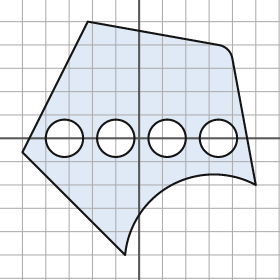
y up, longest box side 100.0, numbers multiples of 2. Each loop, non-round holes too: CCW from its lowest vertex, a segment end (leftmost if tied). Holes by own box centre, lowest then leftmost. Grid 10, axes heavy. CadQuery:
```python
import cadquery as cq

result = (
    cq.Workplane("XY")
    .moveTo(-6.0, -50.0)
    .threePointArc((14.0, -20.0), (50.0, -20.0))
    .lineTo(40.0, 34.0)
    .threePointArc((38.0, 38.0), (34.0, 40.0))
    .lineTo(-22.0, 50.0)
    .lineTo(-50.0, -6.0)
    .close()
    .moveTo(-32.0, 0.0)
    .circle(8.0)
    .moveTo(-10.0, 0.0)
    .circle(8.0)
    .moveTo(12.0, 0.0)
    .circle(8.0)
    .moveTo(34.0, 0.0)
    .circle(8.0)
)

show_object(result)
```